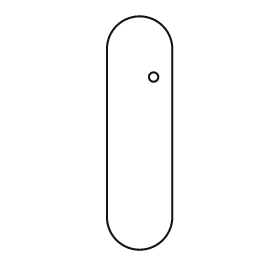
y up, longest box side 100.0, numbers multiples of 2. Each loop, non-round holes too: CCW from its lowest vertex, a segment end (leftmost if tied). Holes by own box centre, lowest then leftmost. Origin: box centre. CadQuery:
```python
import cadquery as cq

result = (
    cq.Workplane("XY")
    .moveTo(-14.0, -36.0)
    .threePointArc((0.0, -50.0), (14.0, -36.0))
    .lineTo(14.0, 36.0)
    .threePointArc((0.0, 50.0), (-14.0, 36.0))
    .close()
    .moveTo(6.0, 24.0)
    .circle(2.0)
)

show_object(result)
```